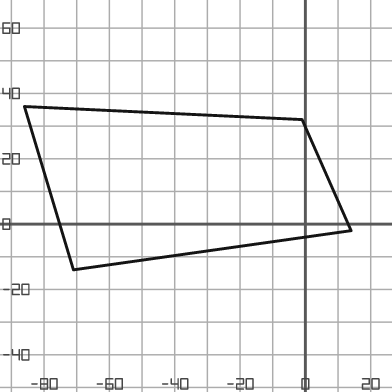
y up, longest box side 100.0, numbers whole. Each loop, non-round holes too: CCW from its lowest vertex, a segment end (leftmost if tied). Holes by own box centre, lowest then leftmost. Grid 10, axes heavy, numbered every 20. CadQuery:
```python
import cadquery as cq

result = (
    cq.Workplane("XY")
    .moveTo(-71.0, -14.0)
    .lineTo(14.0, -2.0)
    .lineTo(-1.0, 32.0)
    .lineTo(-86.0, 36.0)
    .close()
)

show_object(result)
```